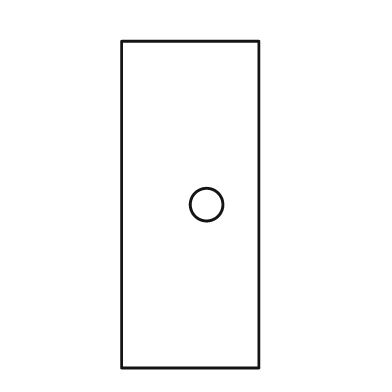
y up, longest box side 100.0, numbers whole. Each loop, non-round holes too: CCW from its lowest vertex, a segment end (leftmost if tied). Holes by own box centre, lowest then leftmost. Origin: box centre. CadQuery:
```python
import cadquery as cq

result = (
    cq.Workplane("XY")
    .moveTo(-21.0, -50.0)
    .lineTo(21.0, -50.0)
    .lineTo(21.0, 50.0)
    .lineTo(-21.0, 50.0)
    .close()
    .moveTo(5.0, 0.0)
    .circle(5.0)
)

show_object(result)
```